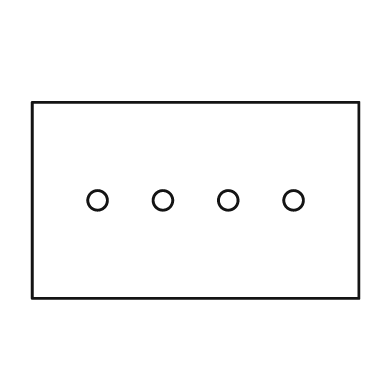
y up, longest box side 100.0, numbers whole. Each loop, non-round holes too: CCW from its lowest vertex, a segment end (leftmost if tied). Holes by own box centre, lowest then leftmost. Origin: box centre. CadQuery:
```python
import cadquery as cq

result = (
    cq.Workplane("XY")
    .moveTo(-50.0, -30.0)
    .lineTo(50.0, -30.0)
    .lineTo(50.0, 30.0)
    .lineTo(-50.0, 30.0)
    .close()
    .moveTo(-30.0, 0.0)
    .circle(3.0)
    .moveTo(-10.0, 0.0)
    .circle(3.0)
    .moveTo(10.0, 0.0)
    .circle(3.0)
    .moveTo(30.0, 0.0)
    .circle(3.0)
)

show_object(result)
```